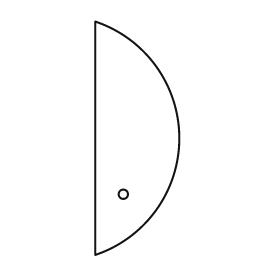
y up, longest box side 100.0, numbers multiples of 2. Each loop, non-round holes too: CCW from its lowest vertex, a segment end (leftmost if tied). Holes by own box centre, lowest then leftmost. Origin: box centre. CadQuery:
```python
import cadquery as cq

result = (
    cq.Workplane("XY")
    .moveTo(-18.0, -50.0)
    .threePointArc((18.0, 0.0), (-18.0, 50.0))
    .close()
    .moveTo(-6.0, -24.0)
    .circle(2.0)
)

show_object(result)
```